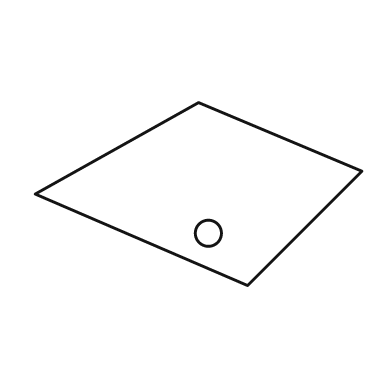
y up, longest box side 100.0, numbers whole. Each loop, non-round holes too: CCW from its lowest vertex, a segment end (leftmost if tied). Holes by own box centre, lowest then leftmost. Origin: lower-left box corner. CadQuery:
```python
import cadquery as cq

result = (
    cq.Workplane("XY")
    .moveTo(65.0, 0.0)
    .lineTo(100.0, 35.0)
    .lineTo(50.0, 56.0)
    .lineTo(0.0, 28.0)
    .close()
    .moveTo(53.0, 16.0)
    .circle(4.0)
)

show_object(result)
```